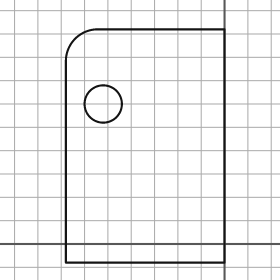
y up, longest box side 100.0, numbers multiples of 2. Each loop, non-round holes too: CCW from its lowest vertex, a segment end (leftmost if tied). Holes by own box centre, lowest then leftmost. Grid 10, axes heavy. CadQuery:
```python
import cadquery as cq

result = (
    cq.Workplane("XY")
    .moveTo(-68.0, -8.0)
    .lineTo(0.0, -8.0)
    .lineTo(0.0, 92.0)
    .lineTo(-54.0, 92.0)
    .threePointArc((-64.0, 88.0), (-68.0, 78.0))
    .close()
    .moveTo(-52.0, 60.0)
    .circle(8.0)
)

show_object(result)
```